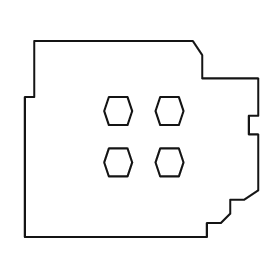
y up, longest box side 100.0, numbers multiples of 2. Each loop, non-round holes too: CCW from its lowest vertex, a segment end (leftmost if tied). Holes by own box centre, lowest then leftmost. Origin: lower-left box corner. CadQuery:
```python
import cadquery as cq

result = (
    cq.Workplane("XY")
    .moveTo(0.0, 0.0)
    .lineTo(78.0, 0.0)
    .lineTo(78.0, 6.0)
    .lineTo(84.0, 6.0)
    .lineTo(88.0, 10.0)
    .lineTo(88.0, 16.0)
    .lineTo(94.0, 16.0)
    .lineTo(100.0, 20.0)
    .lineTo(100.0, 44.0)
    .lineTo(96.0, 44.0)
    .lineTo(96.0, 52.0)
    .lineTo(100.0, 52.0)
    .lineTo(100.0, 68.0)
    .lineTo(76.0, 68.0)
    .lineTo(76.0, 78.0)
    .lineTo(72.0, 84.0)
    .lineTo(4.0, 84.0)
    .lineTo(4.0, 60.0)
    .lineTo(0.0, 60.0)
    .close()
    .moveTo(36.0, 26.0)
    .lineTo(44.0, 26.0)
    .lineTo(46.0, 32.0)
    .lineTo(44.0, 38.0)
    .lineTo(36.0, 38.0)
    .lineTo(34.0, 32.0)
    .close()
    .moveTo(58.0, 26.0)
    .lineTo(66.0, 26.0)
    .lineTo(68.0, 32.0)
    .lineTo(66.0, 38.0)
    .lineTo(58.0, 38.0)
    .lineTo(56.0, 32.0)
    .close()
    .moveTo(36.0, 48.0)
    .lineTo(44.0, 48.0)
    .lineTo(46.0, 54.0)
    .lineTo(44.0, 60.0)
    .lineTo(36.0, 60.0)
    .lineTo(34.0, 54.0)
    .close()
    .moveTo(58.0, 48.0)
    .lineTo(66.0, 48.0)
    .lineTo(68.0, 54.0)
    .lineTo(66.0, 60.0)
    .lineTo(58.0, 60.0)
    .lineTo(56.0, 54.0)
    .close()
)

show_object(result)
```